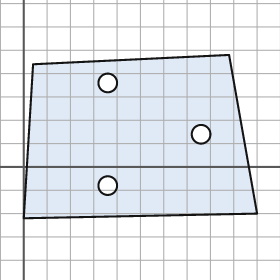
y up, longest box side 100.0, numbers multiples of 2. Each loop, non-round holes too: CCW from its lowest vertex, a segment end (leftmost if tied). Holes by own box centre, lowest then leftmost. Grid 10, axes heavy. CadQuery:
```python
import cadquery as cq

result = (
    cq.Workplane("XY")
    .moveTo(0.0, -22.0)
    .lineTo(100.0, -20.0)
    .lineTo(88.0, 48.0)
    .lineTo(4.0, 44.0)
    .close()
    .moveTo(36.0, -8.0)
    .circle(4.0)
    .moveTo(76.0, 14.0)
    .circle(4.0)
    .moveTo(36.0, 36.0)
    .circle(4.0)
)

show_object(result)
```